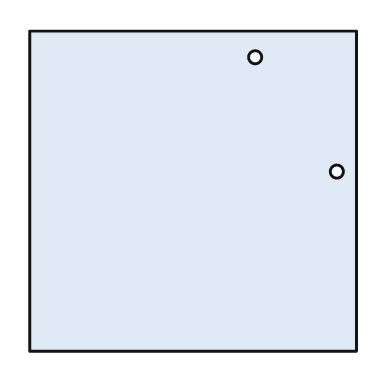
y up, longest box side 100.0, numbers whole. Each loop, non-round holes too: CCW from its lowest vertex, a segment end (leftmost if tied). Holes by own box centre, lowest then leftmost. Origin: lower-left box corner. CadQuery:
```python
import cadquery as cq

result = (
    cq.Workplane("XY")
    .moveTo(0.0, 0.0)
    .lineTo(100.0, 0.0)
    .lineTo(100.0, 98.0)
    .lineTo(0.0, 98.0)
    .close()
    .moveTo(94.0, 55.0)
    .circle(2.0)
    .moveTo(69.0, 90.0)
    .circle(2.0)
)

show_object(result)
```